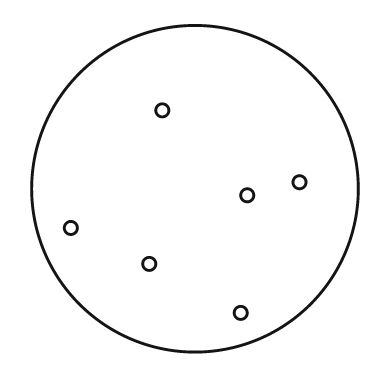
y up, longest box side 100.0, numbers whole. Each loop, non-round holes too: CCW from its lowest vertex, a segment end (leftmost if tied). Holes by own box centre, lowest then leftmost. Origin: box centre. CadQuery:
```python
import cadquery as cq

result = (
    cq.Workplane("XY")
    .moveTo(0.0, 0.0)
    .circle(50.0)
    .moveTo(14.0, -38.0)
    .circle(2.0)
    .moveTo(-14.0, -23.0)
    .circle(2.0)
    .moveTo(-38.0, -12.0)
    .circle(2.0)
    .moveTo(16.0, -2.0)
    .circle(2.0)
    .moveTo(32.0, 2.0)
    .circle(2.0)
    .moveTo(-10.0, 24.0)
    .circle(2.0)
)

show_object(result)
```